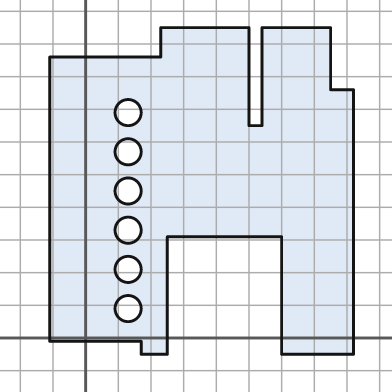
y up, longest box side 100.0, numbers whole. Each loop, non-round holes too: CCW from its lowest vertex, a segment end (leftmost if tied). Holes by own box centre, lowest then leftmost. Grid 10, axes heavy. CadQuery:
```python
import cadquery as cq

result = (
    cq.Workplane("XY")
    .moveTo(17.0, -5.0)
    .lineTo(25.0, -5.0)
    .lineTo(25.0, 31.0)
    .lineTo(60.0, 31.0)
    .lineTo(60.0, -5.0)
    .lineTo(82.0, -5.0)
    .lineTo(82.0, 76.0)
    .lineTo(75.0, 76.0)
    .lineTo(75.0, 95.0)
    .lineTo(54.0, 95.0)
    .lineTo(54.0, 65.0)
    .lineTo(50.0, 65.0)
    .lineTo(50.0, 95.0)
    .lineTo(23.0, 95.0)
    .lineTo(23.0, 86.0)
    .lineTo(-11.0, 86.0)
    .lineTo(-11.0, -1.0)
    .lineTo(17.0, -1.0)
    .close()
    .moveTo(13.0, 9.0)
    .circle(4.0)
    .moveTo(13.0, 21.0)
    .circle(4.0)
    .moveTo(13.0, 33.0)
    .circle(4.0)
    .moveTo(13.0, 45.0)
    .circle(4.0)
    .moveTo(13.0, 57.0)
    .circle(4.0)
    .moveTo(13.0, 69.0)
    .circle(4.0)
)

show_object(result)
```